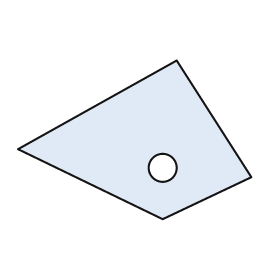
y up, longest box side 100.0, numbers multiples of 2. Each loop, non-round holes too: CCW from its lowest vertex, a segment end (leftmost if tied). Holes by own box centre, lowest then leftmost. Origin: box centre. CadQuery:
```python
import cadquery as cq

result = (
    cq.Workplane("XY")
    .moveTo(12.0, -34.0)
    .lineTo(50.0, -16.0)
    .lineTo(18.0, 34.0)
    .lineTo(-50.0, -4.0)
    .close()
    .moveTo(12.0, -12.0)
    .circle(6.0)
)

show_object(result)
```